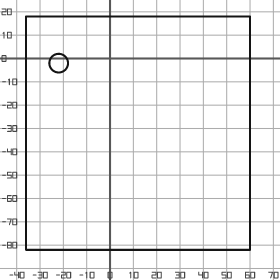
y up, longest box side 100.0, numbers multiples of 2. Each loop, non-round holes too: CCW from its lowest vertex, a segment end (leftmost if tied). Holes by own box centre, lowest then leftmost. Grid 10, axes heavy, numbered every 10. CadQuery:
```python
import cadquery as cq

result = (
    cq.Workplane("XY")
    .moveTo(-36.0, -82.0)
    .lineTo(60.0, -82.0)
    .lineTo(60.0, 18.0)
    .lineTo(-36.0, 18.0)
    .close()
    .moveTo(-22.0, -2.0)
    .circle(4.0)
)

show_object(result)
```